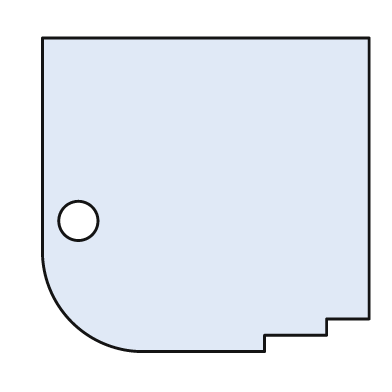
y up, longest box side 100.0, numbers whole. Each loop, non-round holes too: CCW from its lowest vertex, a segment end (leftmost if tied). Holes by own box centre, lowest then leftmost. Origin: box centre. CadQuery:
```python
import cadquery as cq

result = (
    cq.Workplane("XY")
    .moveTo(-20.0, -48.0)
    .lineTo(18.0, -48.0)
    .lineTo(18.0, -43.0)
    .lineTo(37.0, -43.0)
    .lineTo(37.0, -38.0)
    .lineTo(50.0, -38.0)
    .lineTo(50.0, 48.0)
    .lineTo(-50.0, 48.0)
    .lineTo(-50.0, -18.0)
    .threePointArc((-41.0, -39.0), (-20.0, -48.0))
    .close()
    .moveTo(-39.0, -8.0)
    .circle(6.0)
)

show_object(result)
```